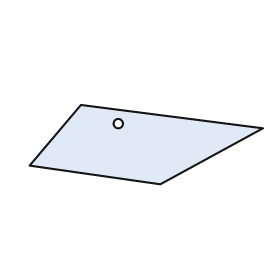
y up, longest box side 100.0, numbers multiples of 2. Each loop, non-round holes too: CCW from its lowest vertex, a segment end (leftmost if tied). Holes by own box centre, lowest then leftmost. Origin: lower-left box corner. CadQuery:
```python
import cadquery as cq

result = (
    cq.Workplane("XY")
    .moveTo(56.0, 0.0)
    .lineTo(100.0, 24.0)
    .lineTo(22.0, 34.0)
    .lineTo(0.0, 8.0)
    .close()
    .moveTo(38.0, 26.0)
    .circle(2.0)
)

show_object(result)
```